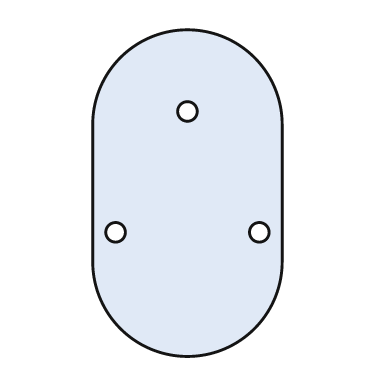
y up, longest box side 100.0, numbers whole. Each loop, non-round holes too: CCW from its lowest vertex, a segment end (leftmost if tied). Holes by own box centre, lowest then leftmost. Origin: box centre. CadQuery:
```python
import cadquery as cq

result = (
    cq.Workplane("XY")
    .moveTo(-29.0, -21.0)
    .threePointArc((0.0, -50.0), (29.0, -21.0))
    .lineTo(29.0, 21.0)
    .threePointArc((0.0, 50.0), (-29.0, 21.0))
    .close()
    .moveTo(-22.0, -12.0)
    .circle(3.0)
    .moveTo(22.0, -12.0)
    .circle(3.0)
    .moveTo(0.0, 25.0)
    .circle(3.0)
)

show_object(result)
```